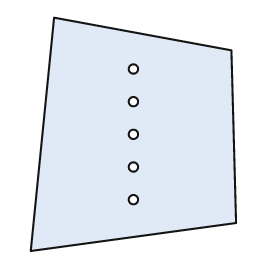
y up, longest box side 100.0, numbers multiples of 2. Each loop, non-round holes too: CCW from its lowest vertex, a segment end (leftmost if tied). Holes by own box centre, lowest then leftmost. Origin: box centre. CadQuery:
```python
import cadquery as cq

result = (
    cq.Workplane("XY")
    .moveTo(-44.0, -50.0)
    .lineTo(44.0, -38.0)
    .lineTo(42.0, 36.0)
    .lineTo(-34.0, 50.0)
    .close()
    .moveTo(0.0, -28.0)
    .circle(2.0)
    .moveTo(0.0, -14.0)
    .circle(2.0)
    .moveTo(0.0, 0.0)
    .circle(2.0)
    .moveTo(0.0, 14.0)
    .circle(2.0)
    .moveTo(0.0, 28.0)
    .circle(2.0)
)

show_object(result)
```